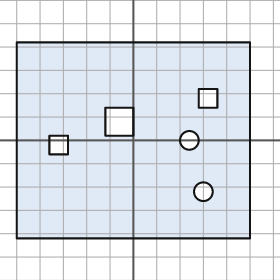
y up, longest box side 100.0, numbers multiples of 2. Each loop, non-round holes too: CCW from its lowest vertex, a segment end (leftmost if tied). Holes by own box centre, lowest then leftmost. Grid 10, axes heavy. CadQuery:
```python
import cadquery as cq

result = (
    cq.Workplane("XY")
    .moveTo(-50.0, -42.0)
    .lineTo(50.0, -42.0)
    .lineTo(50.0, 42.0)
    .lineTo(-50.0, 42.0)
    .close()
    .moveTo(30.0, -22.0)
    .circle(4.0)
    .moveTo(-36.0, -6.0)
    .lineTo(-28.0, -6.0)
    .lineTo(-28.0, 2.0)
    .lineTo(-36.0, 2.0)
    .close()
    .moveTo(24.0, 0.0)
    .circle(4.0)
    .moveTo(-12.0, 2.0)
    .lineTo(0.0, 2.0)
    .lineTo(0.0, 14.0)
    .lineTo(-12.0, 14.0)
    .close()
    .moveTo(28.0, 14.0)
    .lineTo(36.0, 14.0)
    .lineTo(36.0, 22.0)
    .lineTo(28.0, 22.0)
    .close()
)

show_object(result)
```